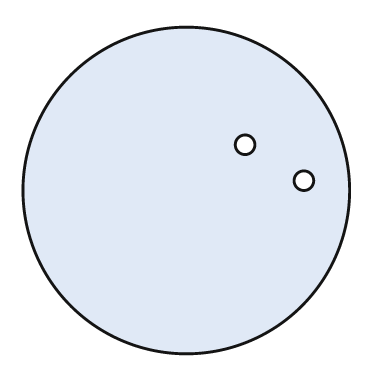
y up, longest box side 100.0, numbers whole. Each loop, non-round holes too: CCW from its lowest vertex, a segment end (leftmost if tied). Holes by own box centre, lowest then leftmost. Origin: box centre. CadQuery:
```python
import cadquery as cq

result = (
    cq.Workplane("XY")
    .moveTo(0.0, 0.0)
    .circle(50.0)
    .moveTo(36.0, 3.0)
    .circle(3.0)
    .moveTo(18.0, 14.0)
    .circle(3.0)
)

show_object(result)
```